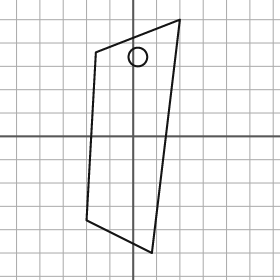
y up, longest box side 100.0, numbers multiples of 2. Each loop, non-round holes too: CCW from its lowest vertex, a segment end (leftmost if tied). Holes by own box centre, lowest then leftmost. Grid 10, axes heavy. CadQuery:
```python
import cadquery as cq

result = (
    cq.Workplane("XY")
    .moveTo(8.0, -50.0)
    .lineTo(20.0, 50.0)
    .lineTo(-16.0, 36.0)
    .lineTo(-20.0, -36.0)
    .close()
    .moveTo(2.0, 34.0)
    .circle(4.0)
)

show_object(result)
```